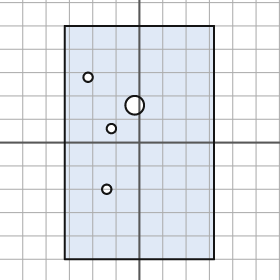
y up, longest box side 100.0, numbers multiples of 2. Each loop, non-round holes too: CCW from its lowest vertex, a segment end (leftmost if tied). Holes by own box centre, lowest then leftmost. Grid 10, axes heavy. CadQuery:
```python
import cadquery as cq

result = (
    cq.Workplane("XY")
    .moveTo(-32.0, -50.0)
    .lineTo(32.0, -50.0)
    .lineTo(32.0, 50.0)
    .lineTo(-32.0, 50.0)
    .close()
    .moveTo(-14.0, -20.0)
    .circle(2.0)
    .moveTo(-12.0, 6.0)
    .circle(2.0)
    .moveTo(-2.0, 16.0)
    .circle(4.0)
    .moveTo(-22.0, 28.0)
    .circle(2.0)
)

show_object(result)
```